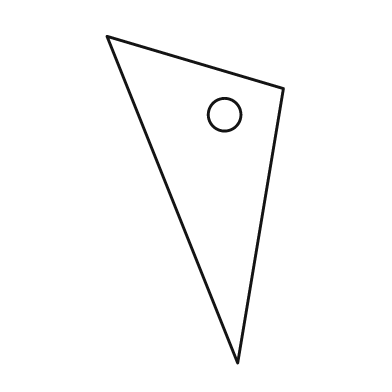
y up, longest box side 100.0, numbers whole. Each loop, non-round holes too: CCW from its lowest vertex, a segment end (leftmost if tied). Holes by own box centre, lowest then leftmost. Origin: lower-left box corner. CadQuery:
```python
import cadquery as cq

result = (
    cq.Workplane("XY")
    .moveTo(40.0, 0.0)
    .lineTo(54.0, 84.0)
    .lineTo(0.0, 100.0)
    .close()
    .moveTo(36.0, 76.0)
    .circle(5.0)
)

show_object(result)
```